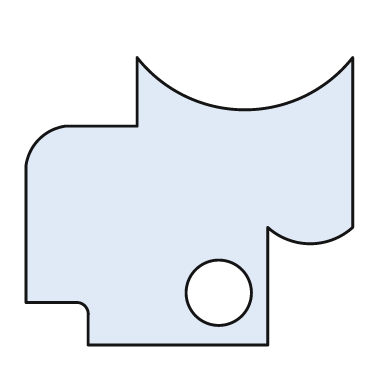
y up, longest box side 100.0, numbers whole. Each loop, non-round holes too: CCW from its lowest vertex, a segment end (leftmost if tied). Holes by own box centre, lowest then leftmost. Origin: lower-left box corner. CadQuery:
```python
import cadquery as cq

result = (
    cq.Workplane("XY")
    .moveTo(19.0, 0.0)
    .lineTo(74.0, 0.0)
    .lineTo(74.0, 36.0)
    .threePointArc((87.0, 31.0), (100.0, 36.0))
    .lineTo(100.0, 88.0)
    .threePointArc((67.0, 72.0), (34.0, 88.0))
    .lineTo(34.0, 67.0)
    .lineTo(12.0, 67.0)
    .threePointArc((4.0, 63.0), (0.0, 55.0))
    .lineTo(0.0, 13.0)
    .lineTo(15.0, 13.0)
    .threePointArc((18.0, 12.0), (19.0, 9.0))
    .close()
    .moveTo(59.0, 16.0)
    .circle(10.0)
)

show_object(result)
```